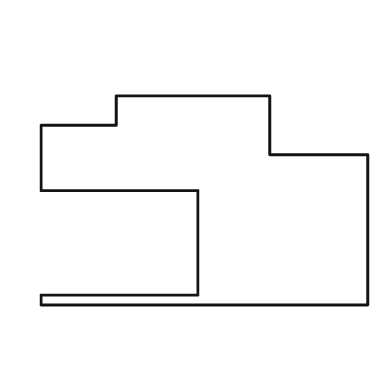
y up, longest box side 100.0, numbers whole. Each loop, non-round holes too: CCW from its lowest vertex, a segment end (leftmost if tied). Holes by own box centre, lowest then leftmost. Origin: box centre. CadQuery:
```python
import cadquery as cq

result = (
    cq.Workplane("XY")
    .moveTo(-50.0, -32.0)
    .lineTo(50.0, -32.0)
    .lineTo(50.0, 14.0)
    .lineTo(20.0, 14.0)
    .lineTo(20.0, 32.0)
    .lineTo(-27.0, 32.0)
    .lineTo(-27.0, 23.0)
    .lineTo(-50.0, 23.0)
    .lineTo(-50.0, 3.0)
    .lineTo(-2.0, 3.0)
    .lineTo(-2.0, -29.0)
    .lineTo(-50.0, -29.0)
    .close()
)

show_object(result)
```